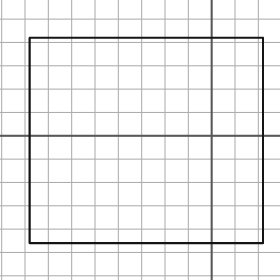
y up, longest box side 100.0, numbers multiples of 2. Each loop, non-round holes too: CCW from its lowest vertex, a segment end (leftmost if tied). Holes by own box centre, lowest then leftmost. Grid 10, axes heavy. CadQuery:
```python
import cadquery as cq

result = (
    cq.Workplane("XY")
    .moveTo(-78.0, -46.0)
    .lineTo(22.0, -46.0)
    .lineTo(22.0, 42.0)
    .lineTo(-78.0, 42.0)
    .close()
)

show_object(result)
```